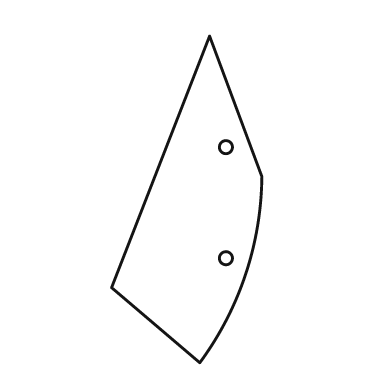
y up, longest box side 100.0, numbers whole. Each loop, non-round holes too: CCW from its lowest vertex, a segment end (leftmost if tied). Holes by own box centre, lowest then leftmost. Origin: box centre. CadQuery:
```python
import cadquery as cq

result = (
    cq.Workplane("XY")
    .moveTo(4.0, -50.0)
    .threePointArc((18.0, -23.0), (23.0, 7.0))
    .lineTo(7.0, 50.0)
    .lineTo(-23.0, -27.0)
    .close()
    .moveTo(12.0, -18.0)
    .circle(2.0)
    .moveTo(12.0, 16.0)
    .circle(2.0)
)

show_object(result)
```